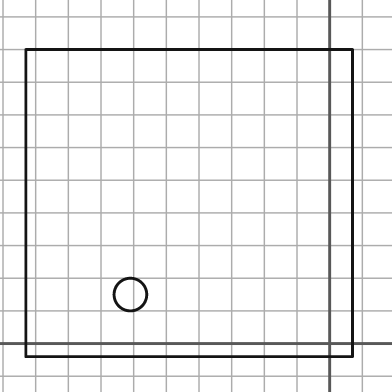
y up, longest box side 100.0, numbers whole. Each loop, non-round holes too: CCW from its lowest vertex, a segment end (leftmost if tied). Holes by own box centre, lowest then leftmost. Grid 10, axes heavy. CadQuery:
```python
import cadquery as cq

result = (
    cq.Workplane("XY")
    .moveTo(-93.0, -4.0)
    .lineTo(7.0, -4.0)
    .lineTo(7.0, 90.0)
    .lineTo(-93.0, 90.0)
    .close()
    .moveTo(-61.0, 15.0)
    .circle(5.0)
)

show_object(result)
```